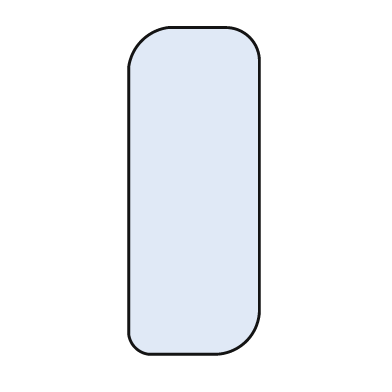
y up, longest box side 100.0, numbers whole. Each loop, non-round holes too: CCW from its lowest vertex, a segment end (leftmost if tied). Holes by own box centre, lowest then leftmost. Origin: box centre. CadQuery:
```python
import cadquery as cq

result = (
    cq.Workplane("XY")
    .moveTo(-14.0, -50.0)
    .lineTo(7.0, -50.0)
    .threePointArc((16.0, -46.0), (20.0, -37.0))
    .lineTo(20.0, 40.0)
    .threePointArc((17.0, 47.0), (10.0, 50.0))
    .lineTo(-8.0, 50.0)
    .threePointArc((-16.0, 46.0), (-20.0, 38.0))
    .lineTo(-20.0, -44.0)
    .threePointArc((-18.0, -48.0), (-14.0, -50.0))
    .close()
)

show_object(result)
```